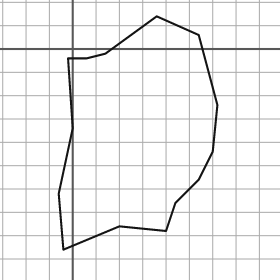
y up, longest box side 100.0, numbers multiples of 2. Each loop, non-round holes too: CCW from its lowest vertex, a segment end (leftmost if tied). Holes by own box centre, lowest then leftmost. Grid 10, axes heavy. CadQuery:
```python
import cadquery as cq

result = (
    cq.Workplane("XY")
    .moveTo(-4.0, -86.0)
    .lineTo(20.0, -76.0)
    .lineTo(40.0, -78.0)
    .lineTo(44.0, -66.0)
    .lineTo(54.0, -56.0)
    .lineTo(60.0, -44.0)
    .lineTo(62.0, -24.0)
    .lineTo(54.0, 6.0)
    .lineTo(36.0, 14.0)
    .lineTo(14.0, -2.0)
    .lineTo(6.0, -4.0)
    .lineTo(-2.0, -4.0)
    .lineTo(0.0, -34.0)
    .lineTo(-6.0, -62.0)
    .close()
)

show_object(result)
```